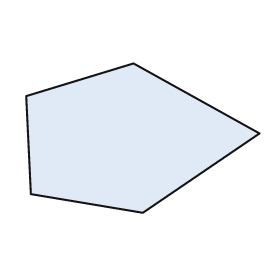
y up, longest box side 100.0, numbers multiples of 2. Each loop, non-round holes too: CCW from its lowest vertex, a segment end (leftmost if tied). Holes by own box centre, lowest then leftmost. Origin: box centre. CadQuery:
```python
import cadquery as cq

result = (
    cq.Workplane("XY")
    .moveTo(0.0, -32.0)
    .lineTo(50.0, 2.0)
    .lineTo(-4.0, 32.0)
    .lineTo(-50.0, 18.0)
    .lineTo(-48.0, -24.0)
    .close()
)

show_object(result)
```